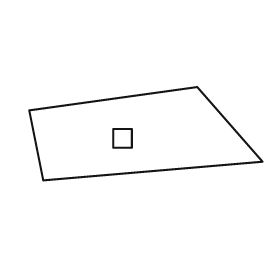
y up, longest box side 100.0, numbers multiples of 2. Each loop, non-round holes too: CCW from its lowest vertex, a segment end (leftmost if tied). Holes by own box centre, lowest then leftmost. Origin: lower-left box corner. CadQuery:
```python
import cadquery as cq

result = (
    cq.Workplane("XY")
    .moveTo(6.0, 0.0)
    .lineTo(100.0, 8.0)
    .lineTo(72.0, 40.0)
    .lineTo(0.0, 30.0)
    .close()
    .moveTo(36.0, 14.0)
    .lineTo(44.0, 14.0)
    .lineTo(44.0, 22.0)
    .lineTo(36.0, 22.0)
    .close()
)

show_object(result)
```